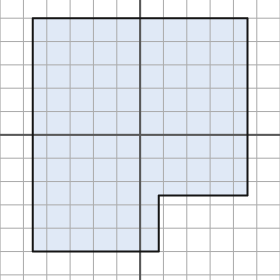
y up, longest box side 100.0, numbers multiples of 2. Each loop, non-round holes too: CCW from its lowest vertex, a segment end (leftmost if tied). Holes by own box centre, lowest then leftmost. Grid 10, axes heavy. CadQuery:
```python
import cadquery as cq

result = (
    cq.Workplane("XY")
    .moveTo(-46.0, -50.0)
    .lineTo(8.0, -50.0)
    .lineTo(8.0, -26.0)
    .lineTo(46.0, -26.0)
    .lineTo(46.0, 50.0)
    .lineTo(-46.0, 50.0)
    .close()
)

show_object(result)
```